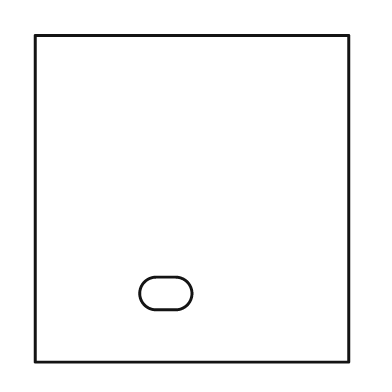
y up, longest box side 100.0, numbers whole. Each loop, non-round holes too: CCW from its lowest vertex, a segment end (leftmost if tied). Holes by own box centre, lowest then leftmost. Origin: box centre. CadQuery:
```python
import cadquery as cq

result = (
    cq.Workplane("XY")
    .moveTo(-48.0, -50.0)
    .lineTo(48.0, -50.0)
    .lineTo(48.0, 50.0)
    .lineTo(-48.0, 50.0)
    .close()
    .moveTo(-11.0, -34.0)
    .lineTo(-5.0, -34.0)
    .threePointArc((0.0, -29.0), (-5.0, -24.0))
    .lineTo(-11.0, -24.0)
    .threePointArc((-16.0, -29.0), (-11.0, -34.0))
    .close()
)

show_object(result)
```